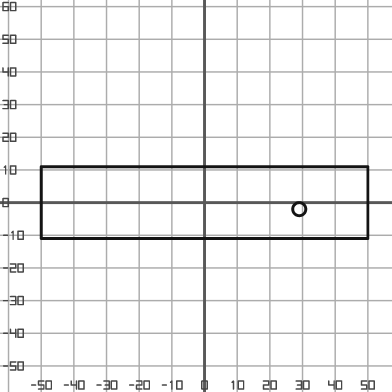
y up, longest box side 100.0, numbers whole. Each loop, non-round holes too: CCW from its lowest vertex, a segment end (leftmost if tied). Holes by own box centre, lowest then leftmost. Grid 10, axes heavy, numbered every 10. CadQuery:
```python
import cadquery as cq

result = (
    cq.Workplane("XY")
    .moveTo(-50.0, -11.0)
    .lineTo(50.0, -11.0)
    .lineTo(50.0, 11.0)
    .lineTo(-50.0, 11.0)
    .close()
    .moveTo(29.0, -2.0)
    .circle(2.0)
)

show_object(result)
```